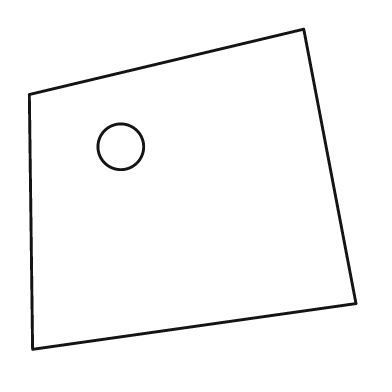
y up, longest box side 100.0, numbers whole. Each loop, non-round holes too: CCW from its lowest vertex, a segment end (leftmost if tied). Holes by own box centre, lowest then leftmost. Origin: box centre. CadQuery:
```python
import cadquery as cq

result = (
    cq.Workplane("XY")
    .moveTo(-49.0, -49.0)
    .lineTo(50.0, -35.0)
    .lineTo(34.0, 49.0)
    .lineTo(-50.0, 29.0)
    .close()
    .moveTo(-22.0, 13.0)
    .circle(7.0)
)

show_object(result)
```